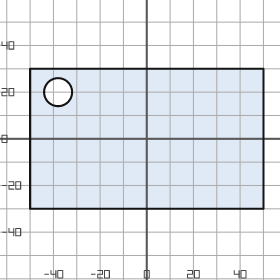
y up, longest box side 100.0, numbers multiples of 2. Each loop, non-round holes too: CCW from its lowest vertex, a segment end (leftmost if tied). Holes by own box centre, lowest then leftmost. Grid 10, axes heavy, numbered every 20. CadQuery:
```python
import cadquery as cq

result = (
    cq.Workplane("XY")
    .moveTo(-50.0, -30.0)
    .lineTo(50.0, -30.0)
    .lineTo(50.0, 30.0)
    .lineTo(-50.0, 30.0)
    .close()
    .moveTo(-38.0, 20.0)
    .circle(6.0)
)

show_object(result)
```